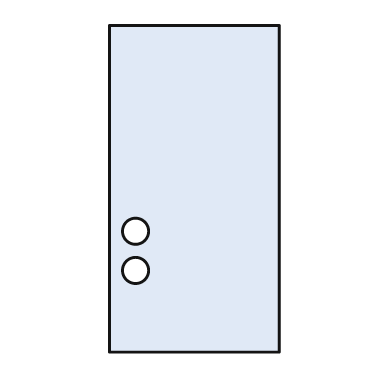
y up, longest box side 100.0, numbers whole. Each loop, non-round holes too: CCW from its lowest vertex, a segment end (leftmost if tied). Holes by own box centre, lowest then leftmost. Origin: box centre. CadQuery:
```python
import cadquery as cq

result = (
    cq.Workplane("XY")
    .moveTo(-26.0, -50.0)
    .lineTo(26.0, -50.0)
    .lineTo(26.0, 50.0)
    .lineTo(-26.0, 50.0)
    .close()
    .moveTo(-18.0, -25.0)
    .circle(4.0)
    .moveTo(-18.0, -13.0)
    .circle(4.0)
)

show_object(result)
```